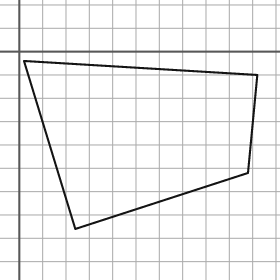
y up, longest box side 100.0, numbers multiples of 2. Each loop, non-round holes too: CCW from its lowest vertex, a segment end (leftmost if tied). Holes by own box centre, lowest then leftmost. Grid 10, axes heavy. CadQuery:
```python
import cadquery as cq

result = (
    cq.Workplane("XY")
    .moveTo(24.0, -76.0)
    .lineTo(98.0, -52.0)
    .lineTo(102.0, -10.0)
    .lineTo(2.0, -4.0)
    .close()
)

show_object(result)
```